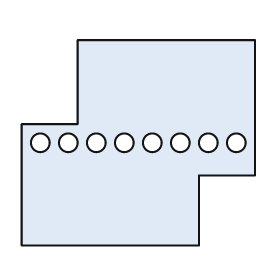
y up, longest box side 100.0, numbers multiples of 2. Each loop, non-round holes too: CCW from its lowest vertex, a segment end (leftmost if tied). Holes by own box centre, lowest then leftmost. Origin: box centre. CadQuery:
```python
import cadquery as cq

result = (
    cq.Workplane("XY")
    .moveTo(-50.0, -44.0)
    .lineTo(26.0, -44.0)
    .lineTo(26.0, -14.0)
    .lineTo(50.0, -14.0)
    .lineTo(50.0, 44.0)
    .lineTo(-26.0, 44.0)
    .lineTo(-26.0, 8.0)
    .lineTo(-50.0, 8.0)
    .close()
    .moveTo(-42.0, 0.0)
    .circle(4.0)
    .moveTo(-30.0, 0.0)
    .circle(4.0)
    .moveTo(-18.0, 0.0)
    .circle(4.0)
    .moveTo(-6.0, 0.0)
    .circle(4.0)
    .moveTo(6.0, 0.0)
    .circle(4.0)
    .moveTo(18.0, 0.0)
    .circle(4.0)
    .moveTo(30.0, 0.0)
    .circle(4.0)
    .moveTo(42.0, 0.0)
    .circle(4.0)
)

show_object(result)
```